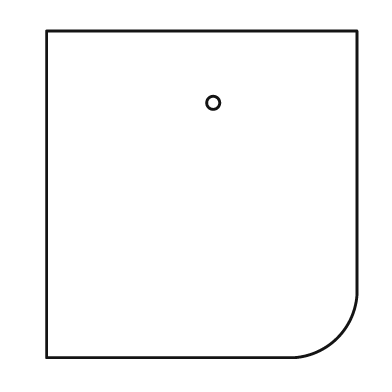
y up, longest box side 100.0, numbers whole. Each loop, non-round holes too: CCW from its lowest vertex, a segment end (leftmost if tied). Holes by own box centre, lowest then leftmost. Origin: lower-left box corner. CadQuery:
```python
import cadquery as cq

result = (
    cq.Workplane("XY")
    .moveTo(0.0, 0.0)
    .lineTo(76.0, 0.0)
    .threePointArc((89.0, 6.0), (95.0, 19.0))
    .lineTo(95.0, 100.0)
    .lineTo(0.0, 100.0)
    .close()
    .moveTo(51.0, 78.0)
    .circle(2.0)
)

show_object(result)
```